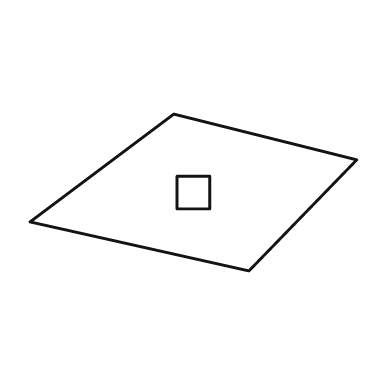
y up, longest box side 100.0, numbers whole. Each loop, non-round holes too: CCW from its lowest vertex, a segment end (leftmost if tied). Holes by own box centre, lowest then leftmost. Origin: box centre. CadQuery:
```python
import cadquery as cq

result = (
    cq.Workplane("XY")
    .moveTo(17.0, -24.0)
    .lineTo(50.0, 10.0)
    .lineTo(-6.0, 24.0)
    .lineTo(-50.0, -9.0)
    .close()
    .moveTo(-5.0, -5.0)
    .lineTo(5.0, -5.0)
    .lineTo(5.0, 5.0)
    .lineTo(-5.0, 5.0)
    .close()
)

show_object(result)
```